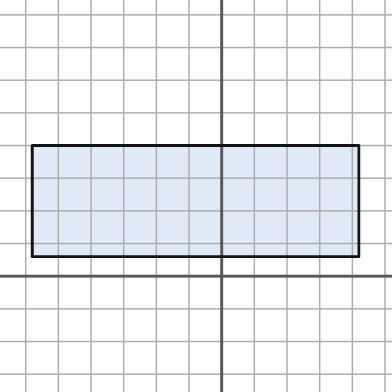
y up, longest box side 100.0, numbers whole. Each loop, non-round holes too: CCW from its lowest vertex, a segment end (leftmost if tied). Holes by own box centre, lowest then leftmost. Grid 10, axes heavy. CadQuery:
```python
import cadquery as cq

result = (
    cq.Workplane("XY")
    .moveTo(-58.0, 6.0)
    .lineTo(42.0, 6.0)
    .lineTo(42.0, 40.0)
    .lineTo(-58.0, 40.0)
    .close()
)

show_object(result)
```